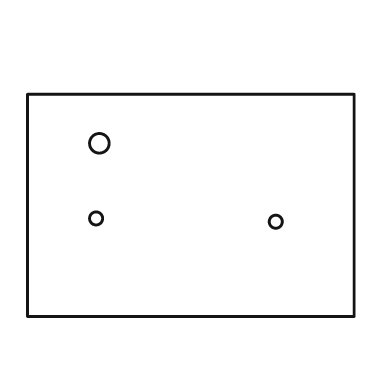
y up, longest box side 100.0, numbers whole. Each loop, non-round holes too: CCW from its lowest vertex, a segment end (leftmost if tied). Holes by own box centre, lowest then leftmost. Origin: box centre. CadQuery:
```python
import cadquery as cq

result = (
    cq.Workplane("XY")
    .moveTo(-50.0, -34.0)
    .lineTo(50.0, -34.0)
    .lineTo(50.0, 34.0)
    .lineTo(-50.0, 34.0)
    .close()
    .moveTo(26.0, -5.0)
    .circle(2.0)
    .moveTo(-29.0, -4.0)
    .circle(2.0)
    .moveTo(-28.0, 19.0)
    .circle(3.0)
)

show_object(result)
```